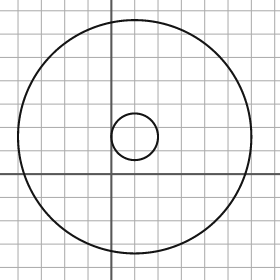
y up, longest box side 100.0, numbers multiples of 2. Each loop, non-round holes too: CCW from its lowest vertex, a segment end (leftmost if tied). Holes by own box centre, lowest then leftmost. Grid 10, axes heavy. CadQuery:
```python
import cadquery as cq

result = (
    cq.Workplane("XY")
    .moveTo(10.0, 16.0)
    .circle(50.0)
    .moveTo(10.0, 16.0)
    .circle(10.0)
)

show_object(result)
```